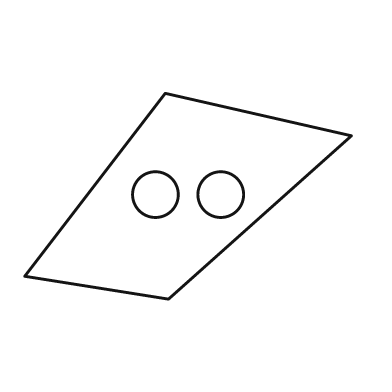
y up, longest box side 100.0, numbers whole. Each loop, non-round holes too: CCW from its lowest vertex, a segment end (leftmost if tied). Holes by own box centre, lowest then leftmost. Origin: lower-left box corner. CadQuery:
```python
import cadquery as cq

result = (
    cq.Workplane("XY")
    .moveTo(44.0, 0.0)
    .lineTo(100.0, 50.0)
    .lineTo(43.0, 63.0)
    .lineTo(0.0, 7.0)
    .close()
    .moveTo(40.0, 32.0)
    .circle(7.0)
    .moveTo(60.0, 32.0)
    .circle(7.0)
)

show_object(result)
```